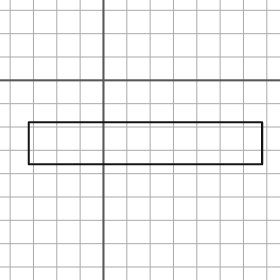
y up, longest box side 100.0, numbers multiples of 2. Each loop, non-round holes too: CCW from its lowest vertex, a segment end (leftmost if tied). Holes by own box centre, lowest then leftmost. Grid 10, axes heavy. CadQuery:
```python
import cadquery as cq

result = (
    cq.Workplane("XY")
    .moveTo(-32.0, -36.0)
    .lineTo(68.0, -36.0)
    .lineTo(68.0, -18.0)
    .lineTo(-32.0, -18.0)
    .close()
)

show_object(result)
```